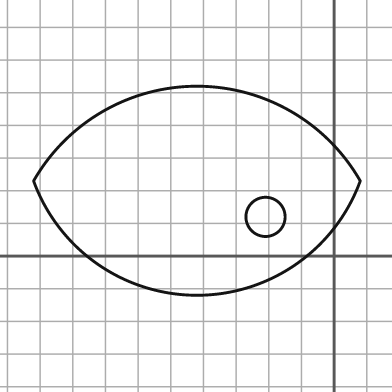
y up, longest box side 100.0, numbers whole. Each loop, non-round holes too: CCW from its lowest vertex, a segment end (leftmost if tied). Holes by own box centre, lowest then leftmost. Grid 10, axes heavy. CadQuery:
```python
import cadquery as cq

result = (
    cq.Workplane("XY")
    .moveTo(-92.0, 23.0)
    .threePointArc((-42.0, -12.0), (8.0, 23.0))
    .threePointArc((-42.0, 52.0), (-92.0, 23.0))
    .close()
    .moveTo(-21.0, 12.0)
    .circle(6.0)
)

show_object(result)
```